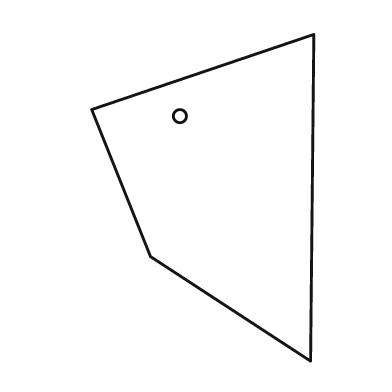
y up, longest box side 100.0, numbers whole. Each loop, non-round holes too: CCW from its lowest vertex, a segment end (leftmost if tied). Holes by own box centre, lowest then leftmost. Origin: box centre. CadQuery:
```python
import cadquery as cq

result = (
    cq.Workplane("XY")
    .moveTo(33.0, -50.0)
    .lineTo(34.0, 50.0)
    .lineTo(-34.0, 27.0)
    .lineTo(-16.0, -18.0)
    .close()
    .moveTo(-7.0, 25.0)
    .circle(2.0)
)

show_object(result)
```